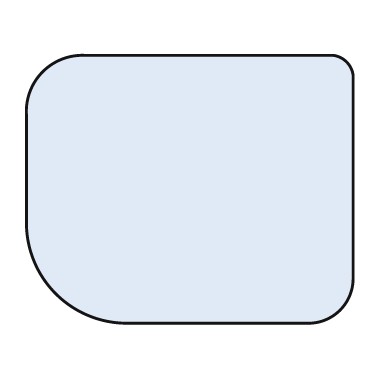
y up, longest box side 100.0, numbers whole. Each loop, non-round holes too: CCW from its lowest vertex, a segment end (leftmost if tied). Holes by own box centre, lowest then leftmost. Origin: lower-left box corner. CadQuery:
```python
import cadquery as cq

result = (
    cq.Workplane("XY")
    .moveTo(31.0, 0.0)
    .lineTo(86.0, 0.0)
    .threePointArc((96.0, 4.0), (100.0, 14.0))
    .lineTo(100.0, 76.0)
    .threePointArc((98.0, 80.0), (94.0, 82.0))
    .lineTo(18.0, 82.0)
    .threePointArc((5.0, 77.0), (0.0, 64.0))
    .lineTo(0.0, 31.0)
    .threePointArc((9.0, 9.0), (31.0, 0.0))
    .close()
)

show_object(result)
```